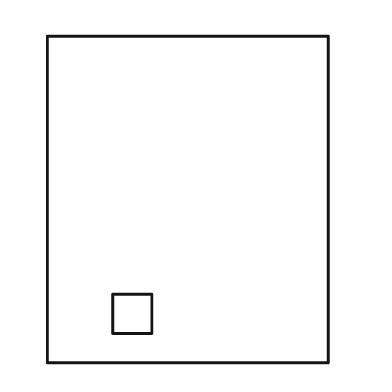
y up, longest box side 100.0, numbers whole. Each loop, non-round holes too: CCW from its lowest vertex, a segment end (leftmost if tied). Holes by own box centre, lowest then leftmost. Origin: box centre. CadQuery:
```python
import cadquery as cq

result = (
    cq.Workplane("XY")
    .moveTo(-43.0, -50.0)
    .lineTo(43.0, -50.0)
    .lineTo(43.0, 50.0)
    .lineTo(-43.0, 50.0)
    .close()
    .moveTo(-23.0, -41.0)
    .lineTo(-11.0, -41.0)
    .lineTo(-11.0, -29.0)
    .lineTo(-23.0, -29.0)
    .close()
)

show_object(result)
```